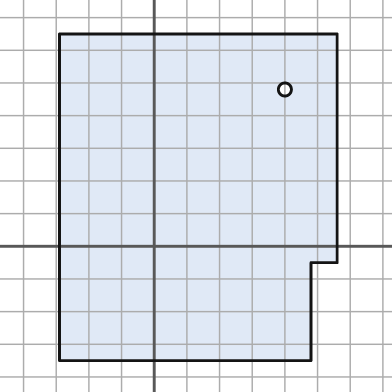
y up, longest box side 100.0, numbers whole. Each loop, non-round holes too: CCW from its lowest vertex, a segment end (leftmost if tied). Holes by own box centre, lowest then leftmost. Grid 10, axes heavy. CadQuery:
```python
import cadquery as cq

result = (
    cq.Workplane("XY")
    .moveTo(-29.0, -35.0)
    .lineTo(48.0, -35.0)
    .lineTo(48.0, -5.0)
    .lineTo(56.0, -5.0)
    .lineTo(56.0, 65.0)
    .lineTo(-29.0, 65.0)
    .close()
    .moveTo(40.0, 48.0)
    .circle(2.0)
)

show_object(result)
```